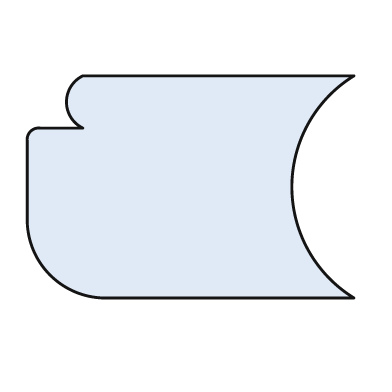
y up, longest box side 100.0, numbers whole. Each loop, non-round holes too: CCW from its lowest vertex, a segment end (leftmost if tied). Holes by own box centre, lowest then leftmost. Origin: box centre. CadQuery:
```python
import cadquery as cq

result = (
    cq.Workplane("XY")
    .moveTo(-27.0, -34.0)
    .lineTo(50.0, -34.0)
    .threePointArc((31.0, 0.0), (50.0, 34.0))
    .lineTo(-33.0, 34.0)
    .threePointArc((-38.0, 26.0), (-33.0, 18.0))
    .lineTo(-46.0, 18.0)
    .threePointArc((-49.0, 17.0), (-50.0, 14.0))
    .lineTo(-50.0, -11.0)
    .threePointArc((-43.0, -27.0), (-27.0, -34.0))
    .close()
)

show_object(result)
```